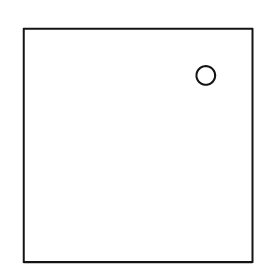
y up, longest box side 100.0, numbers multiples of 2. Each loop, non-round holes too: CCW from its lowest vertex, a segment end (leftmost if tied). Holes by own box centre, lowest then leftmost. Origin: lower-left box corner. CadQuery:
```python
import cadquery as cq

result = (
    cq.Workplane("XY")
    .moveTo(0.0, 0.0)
    .lineTo(98.0, 0.0)
    .lineTo(98.0, 100.0)
    .lineTo(0.0, 100.0)
    .close()
    .moveTo(78.0, 80.0)
    .circle(4.0)
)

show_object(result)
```